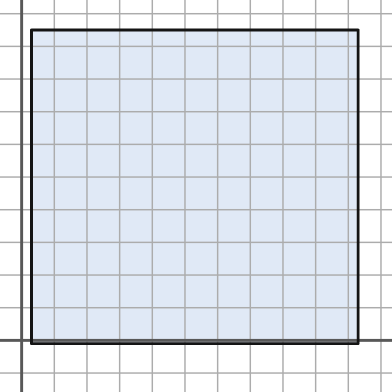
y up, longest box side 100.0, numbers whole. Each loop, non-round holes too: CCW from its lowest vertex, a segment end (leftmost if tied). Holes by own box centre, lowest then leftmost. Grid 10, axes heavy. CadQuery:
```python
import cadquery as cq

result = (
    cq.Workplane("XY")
    .moveTo(3.0, -1.0)
    .lineTo(103.0, -1.0)
    .lineTo(103.0, 95.0)
    .lineTo(3.0, 95.0)
    .close()
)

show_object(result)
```